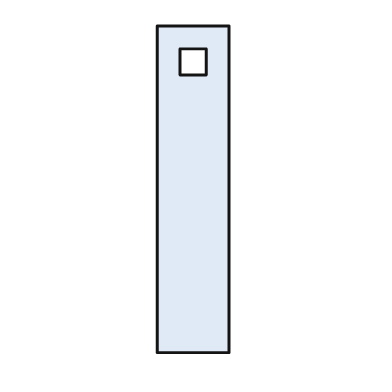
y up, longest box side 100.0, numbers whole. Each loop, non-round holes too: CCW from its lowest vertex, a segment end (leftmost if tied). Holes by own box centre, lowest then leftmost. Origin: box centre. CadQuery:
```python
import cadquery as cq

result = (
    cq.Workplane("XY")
    .moveTo(-11.0, -50.0)
    .lineTo(11.0, -50.0)
    .lineTo(11.0, 50.0)
    .lineTo(-11.0, 50.0)
    .close()
    .moveTo(-4.0, 35.0)
    .lineTo(4.0, 35.0)
    .lineTo(4.0, 43.0)
    .lineTo(-4.0, 43.0)
    .close()
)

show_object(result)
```